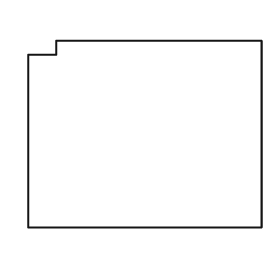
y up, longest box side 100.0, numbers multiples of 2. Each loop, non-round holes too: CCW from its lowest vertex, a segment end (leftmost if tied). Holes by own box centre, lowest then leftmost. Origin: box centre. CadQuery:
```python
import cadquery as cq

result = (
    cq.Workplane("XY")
    .moveTo(-50.0, -40.0)
    .lineTo(50.0, -40.0)
    .lineTo(50.0, 40.0)
    .lineTo(-38.0, 40.0)
    .lineTo(-38.0, 34.0)
    .lineTo(-50.0, 34.0)
    .close()
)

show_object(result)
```